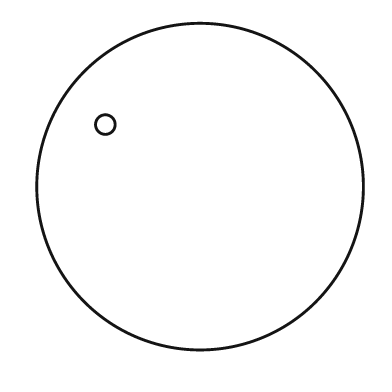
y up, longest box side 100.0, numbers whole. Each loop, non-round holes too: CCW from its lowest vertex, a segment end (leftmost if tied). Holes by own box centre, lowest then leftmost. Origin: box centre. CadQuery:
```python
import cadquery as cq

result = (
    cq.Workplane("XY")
    .moveTo(0.0, 0.0)
    .circle(50.0)
    .moveTo(-29.0, 19.0)
    .circle(3.0)
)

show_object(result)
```